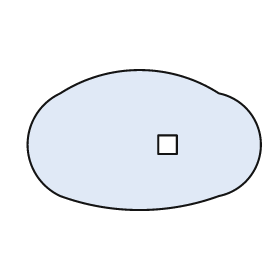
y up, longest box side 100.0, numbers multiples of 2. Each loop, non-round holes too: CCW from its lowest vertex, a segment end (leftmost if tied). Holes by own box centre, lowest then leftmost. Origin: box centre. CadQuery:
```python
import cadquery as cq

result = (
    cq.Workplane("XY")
    .moveTo(-36.0, -24.0)
    .threePointArc((-2.0, -30.0), (32.0, -24.0))
    .threePointArc((50.0, -2.0), (32.0, 20.0))
    .threePointArc((-2.0, 30.0), (-36.0, 20.0))
    .threePointArc((-50.0, -2.0), (-36.0, -24.0))
    .close()
    .moveTo(6.0, -6.0)
    .lineTo(14.0, -6.0)
    .lineTo(14.0, 2.0)
    .lineTo(6.0, 2.0)
    .close()
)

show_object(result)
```